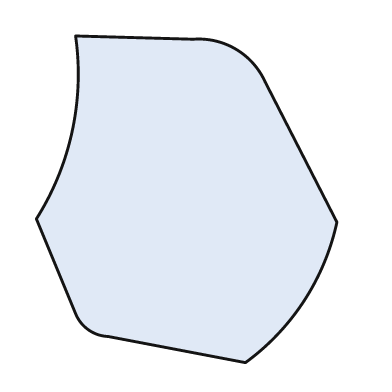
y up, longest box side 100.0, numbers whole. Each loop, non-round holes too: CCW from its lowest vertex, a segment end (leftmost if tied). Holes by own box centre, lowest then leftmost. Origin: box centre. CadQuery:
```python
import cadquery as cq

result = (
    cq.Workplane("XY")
    .moveTo(18.0, -50.0)
    .threePointArc((36.0, -31.0), (46.0, -7.0))
    .lineTo(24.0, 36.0)
    .threePointArc((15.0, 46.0), (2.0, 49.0))
    .lineTo(-34.0, 50.0)
    .threePointArc((-35.0, 21.0), (-46.0, -6.0))
    .lineTo(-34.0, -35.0)
    .threePointArc((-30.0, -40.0), (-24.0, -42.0))
    .close()
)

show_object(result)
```